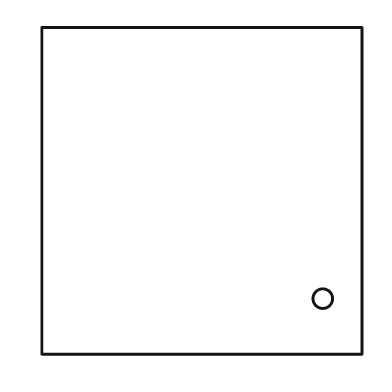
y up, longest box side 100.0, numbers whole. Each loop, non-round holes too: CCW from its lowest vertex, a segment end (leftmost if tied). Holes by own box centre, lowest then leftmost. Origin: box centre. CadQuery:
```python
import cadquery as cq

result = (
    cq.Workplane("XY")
    .moveTo(-49.0, -50.0)
    .lineTo(49.0, -50.0)
    .lineTo(49.0, 50.0)
    .lineTo(-49.0, 50.0)
    .close()
    .moveTo(37.0, -33.0)
    .circle(3.0)
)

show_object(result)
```